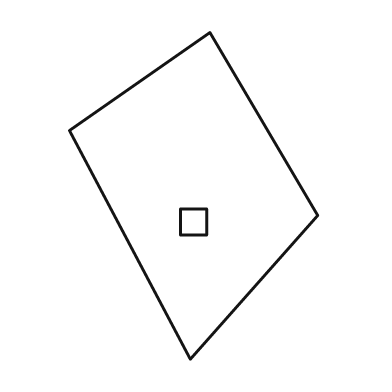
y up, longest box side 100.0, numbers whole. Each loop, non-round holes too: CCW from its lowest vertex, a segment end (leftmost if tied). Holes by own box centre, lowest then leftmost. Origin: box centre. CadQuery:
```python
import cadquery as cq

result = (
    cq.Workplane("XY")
    .moveTo(-1.0, -50.0)
    .lineTo(38.0, -6.0)
    .lineTo(5.0, 50.0)
    .lineTo(-38.0, 20.0)
    .close()
    .moveTo(-4.0, -12.0)
    .lineTo(4.0, -12.0)
    .lineTo(4.0, -4.0)
    .lineTo(-4.0, -4.0)
    .close()
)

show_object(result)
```